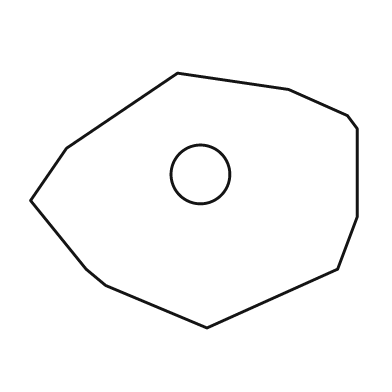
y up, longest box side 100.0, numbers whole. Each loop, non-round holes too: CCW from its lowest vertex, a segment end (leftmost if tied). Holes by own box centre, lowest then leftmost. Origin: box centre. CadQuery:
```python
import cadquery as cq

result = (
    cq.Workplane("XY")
    .moveTo(4.0, -39.0)
    .lineTo(44.0, -21.0)
    .lineTo(50.0, -5.0)
    .lineTo(50.0, 22.0)
    .lineTo(47.0, 26.0)
    .lineTo(29.0, 34.0)
    .lineTo(-5.0, 39.0)
    .lineTo(-39.0, 16.0)
    .lineTo(-50.0, 0.0)
    .lineTo(-33.0, -21.0)
    .lineTo(-27.0, -26.0)
    .close()
    .moveTo(2.0, 8.0)
    .circle(9.0)
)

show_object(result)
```